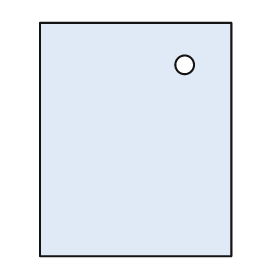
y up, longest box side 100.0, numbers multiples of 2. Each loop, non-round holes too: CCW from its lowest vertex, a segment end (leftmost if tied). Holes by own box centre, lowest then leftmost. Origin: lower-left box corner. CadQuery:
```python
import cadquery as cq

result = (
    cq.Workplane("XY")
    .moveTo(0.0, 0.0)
    .lineTo(82.0, 0.0)
    .lineTo(82.0, 100.0)
    .lineTo(0.0, 100.0)
    .close()
    .moveTo(62.0, 82.0)
    .circle(4.0)
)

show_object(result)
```